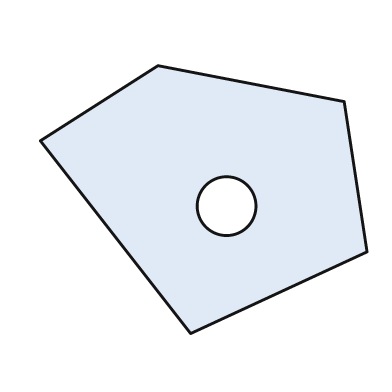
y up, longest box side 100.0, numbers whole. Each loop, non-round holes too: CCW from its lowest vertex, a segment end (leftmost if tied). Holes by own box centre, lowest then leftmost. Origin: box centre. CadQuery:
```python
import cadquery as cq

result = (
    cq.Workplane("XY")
    .moveTo(-4.0, -41.0)
    .lineTo(50.0, -16.0)
    .lineTo(43.0, 30.0)
    .lineTo(-14.0, 41.0)
    .lineTo(-50.0, 18.0)
    .close()
    .moveTo(7.0, -2.0)
    .circle(9.0)
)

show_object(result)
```